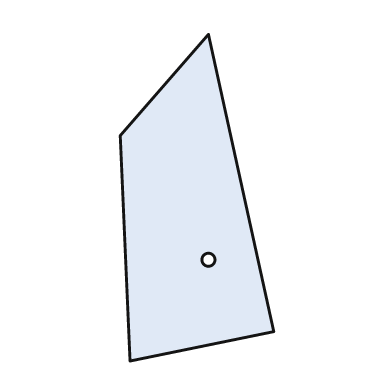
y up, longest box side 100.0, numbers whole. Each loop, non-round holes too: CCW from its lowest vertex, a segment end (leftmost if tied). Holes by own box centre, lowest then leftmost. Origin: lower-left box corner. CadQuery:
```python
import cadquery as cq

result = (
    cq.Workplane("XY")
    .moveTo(3.0, 0.0)
    .lineTo(47.0, 9.0)
    .lineTo(27.0, 100.0)
    .lineTo(0.0, 69.0)
    .close()
    .moveTo(27.0, 31.0)
    .circle(2.0)
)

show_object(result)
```